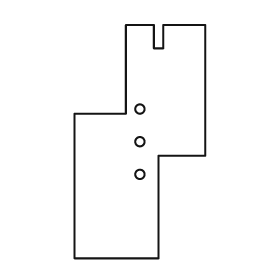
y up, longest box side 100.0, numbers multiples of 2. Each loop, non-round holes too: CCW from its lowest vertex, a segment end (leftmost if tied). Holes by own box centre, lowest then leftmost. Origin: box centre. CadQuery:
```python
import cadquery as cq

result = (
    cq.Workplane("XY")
    .moveTo(-28.0, -50.0)
    .lineTo(8.0, -50.0)
    .lineTo(8.0, -6.0)
    .lineTo(28.0, -6.0)
    .lineTo(28.0, 50.0)
    .lineTo(10.0, 50.0)
    .lineTo(10.0, 40.0)
    .lineTo(6.0, 40.0)
    .lineTo(6.0, 50.0)
    .lineTo(-6.0, 50.0)
    .lineTo(-6.0, 12.0)
    .lineTo(-28.0, 12.0)
    .close()
    .moveTo(0.0, -14.0)
    .circle(2.0)
    .moveTo(0.0, 0.0)
    .circle(2.0)
    .moveTo(0.0, 14.0)
    .circle(2.0)
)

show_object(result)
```